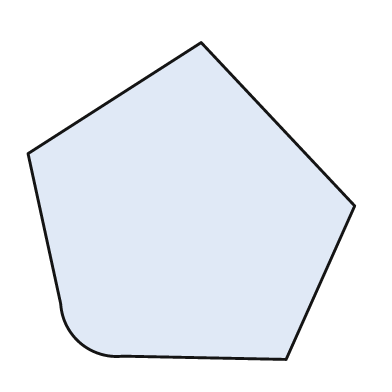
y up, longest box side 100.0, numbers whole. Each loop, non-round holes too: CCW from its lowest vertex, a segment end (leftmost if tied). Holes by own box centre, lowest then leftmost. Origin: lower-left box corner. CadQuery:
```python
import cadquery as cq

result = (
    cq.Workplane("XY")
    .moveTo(79.0, 0.0)
    .lineTo(100.0, 47.0)
    .lineTo(53.0, 97.0)
    .lineTo(0.0, 63.0)
    .lineTo(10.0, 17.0)
    .threePointArc((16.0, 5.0), (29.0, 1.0))
    .close()
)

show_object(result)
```